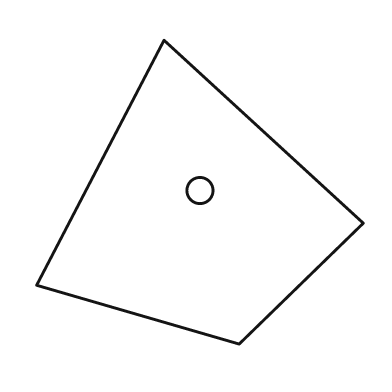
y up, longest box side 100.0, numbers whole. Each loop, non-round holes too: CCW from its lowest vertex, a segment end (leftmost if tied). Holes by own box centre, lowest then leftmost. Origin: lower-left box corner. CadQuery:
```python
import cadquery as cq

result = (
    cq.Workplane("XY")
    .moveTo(62.0, 0.0)
    .lineTo(100.0, 37.0)
    .lineTo(39.0, 93.0)
    .lineTo(0.0, 18.0)
    .close()
    .moveTo(50.0, 47.0)
    .circle(4.0)
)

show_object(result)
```